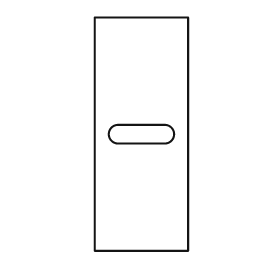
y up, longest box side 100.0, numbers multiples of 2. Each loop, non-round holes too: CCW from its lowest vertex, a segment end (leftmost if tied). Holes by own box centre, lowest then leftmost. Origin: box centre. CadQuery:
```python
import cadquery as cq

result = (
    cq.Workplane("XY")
    .moveTo(-20.0, -50.0)
    .lineTo(20.0, -50.0)
    .lineTo(20.0, 50.0)
    .lineTo(-20.0, 50.0)
    .close()
    .moveTo(-10.0, -4.0)
    .lineTo(10.0, -4.0)
    .threePointArc((14.0, 0.0), (10.0, 4.0))
    .lineTo(-10.0, 4.0)
    .threePointArc((-14.0, 0.0), (-10.0, -4.0))
    .close()
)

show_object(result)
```